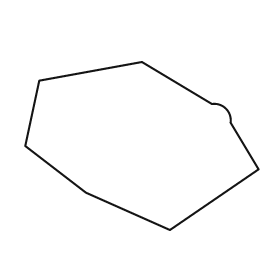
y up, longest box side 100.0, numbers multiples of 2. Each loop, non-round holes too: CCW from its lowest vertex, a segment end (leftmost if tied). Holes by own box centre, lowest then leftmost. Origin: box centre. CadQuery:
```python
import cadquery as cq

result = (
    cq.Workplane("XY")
    .moveTo(12.0, -36.0)
    .lineTo(50.0, -10.0)
    .lineTo(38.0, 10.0)
    .threePointArc((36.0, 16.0), (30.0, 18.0))
    .lineTo(0.0, 36.0)
    .lineTo(-44.0, 28.0)
    .lineTo(-50.0, 0.0)
    .lineTo(-24.0, -20.0)
    .close()
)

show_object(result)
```